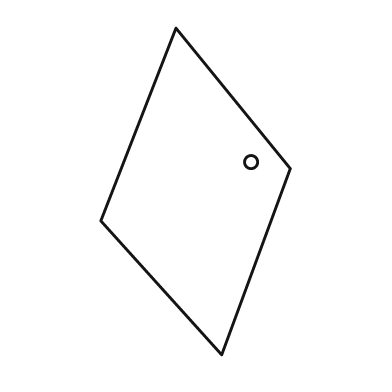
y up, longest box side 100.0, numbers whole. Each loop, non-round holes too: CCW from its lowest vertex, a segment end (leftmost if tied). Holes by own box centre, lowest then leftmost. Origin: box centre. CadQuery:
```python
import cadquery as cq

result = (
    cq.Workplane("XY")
    .moveTo(8.0, -50.0)
    .lineTo(29.0, 7.0)
    .lineTo(-6.0, 50.0)
    .lineTo(-29.0, -9.0)
    .close()
    .moveTo(17.0, 9.0)
    .circle(2.0)
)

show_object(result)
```